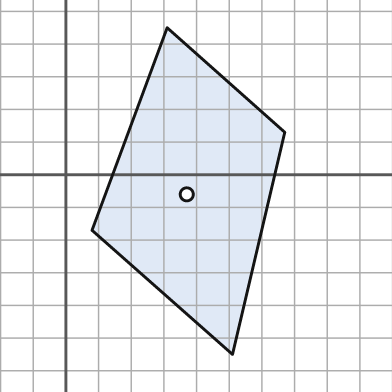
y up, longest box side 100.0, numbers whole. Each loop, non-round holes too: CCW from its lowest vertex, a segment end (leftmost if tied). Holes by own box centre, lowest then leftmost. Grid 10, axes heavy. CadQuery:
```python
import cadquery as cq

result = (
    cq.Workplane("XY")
    .moveTo(51.0, -55.0)
    .lineTo(67.0, 13.0)
    .lineTo(31.0, 45.0)
    .lineTo(8.0, -17.0)
    .close()
    .moveTo(37.0, -6.0)
    .circle(2.0)
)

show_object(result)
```